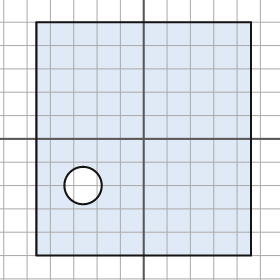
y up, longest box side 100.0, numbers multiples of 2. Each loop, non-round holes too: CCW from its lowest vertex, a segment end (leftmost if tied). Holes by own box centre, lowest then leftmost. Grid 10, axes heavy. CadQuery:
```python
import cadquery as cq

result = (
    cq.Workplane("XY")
    .moveTo(-46.0, -50.0)
    .lineTo(46.0, -50.0)
    .lineTo(46.0, 50.0)
    .lineTo(-46.0, 50.0)
    .close()
    .moveTo(-26.0, -20.0)
    .circle(8.0)
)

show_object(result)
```